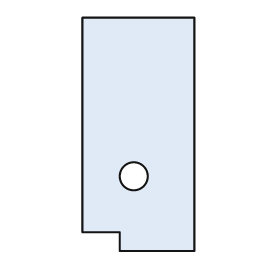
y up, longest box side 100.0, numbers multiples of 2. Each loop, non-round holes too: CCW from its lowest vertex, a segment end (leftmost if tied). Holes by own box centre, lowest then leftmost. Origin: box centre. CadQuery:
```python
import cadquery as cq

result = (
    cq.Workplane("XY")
    .moveTo(-8.0, -50.0)
    .lineTo(24.0, -50.0)
    .lineTo(24.0, 50.0)
    .lineTo(-24.0, 50.0)
    .lineTo(-24.0, -42.0)
    .lineTo(-8.0, -42.0)
    .close()
    .moveTo(-2.0, -18.0)
    .circle(6.0)
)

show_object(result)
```